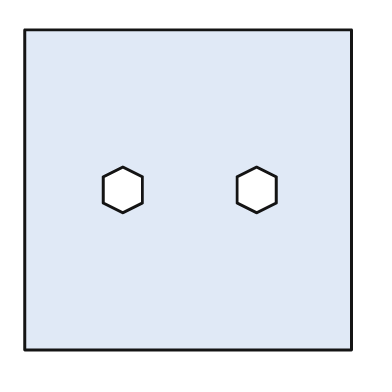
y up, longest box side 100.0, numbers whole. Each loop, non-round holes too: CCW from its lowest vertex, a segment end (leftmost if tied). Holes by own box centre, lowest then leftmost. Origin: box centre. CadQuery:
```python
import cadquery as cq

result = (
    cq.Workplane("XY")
    .moveTo(-50.0, -49.0)
    .lineTo(50.0, -49.0)
    .lineTo(50.0, 49.0)
    .lineTo(-50.0, 49.0)
    .close()
    .moveTo(-20.0, -7.0)
    .lineTo(-14.0, -4.0)
    .lineTo(-14.0, 4.0)
    .lineTo(-20.0, 7.0)
    .lineTo(-26.0, 4.0)
    .lineTo(-26.0, -4.0)
    .close()
    .moveTo(21.0, -7.0)
    .lineTo(27.0, -4.0)
    .lineTo(27.0, 4.0)
    .lineTo(21.0, 7.0)
    .lineTo(15.0, 4.0)
    .lineTo(15.0, -4.0)
    .close()
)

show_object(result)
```